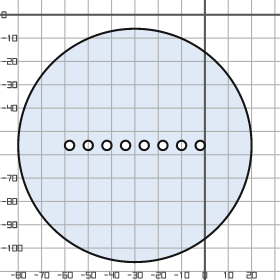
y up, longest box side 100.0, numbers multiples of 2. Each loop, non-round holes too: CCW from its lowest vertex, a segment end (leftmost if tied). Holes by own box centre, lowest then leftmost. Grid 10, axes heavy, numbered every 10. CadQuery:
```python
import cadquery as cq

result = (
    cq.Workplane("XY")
    .moveTo(-30.0, -56.0)
    .circle(50.0)
    .moveTo(-58.0, -56.0)
    .circle(2.0)
    .moveTo(-50.0, -56.0)
    .circle(2.0)
    .moveTo(-42.0, -56.0)
    .circle(2.0)
    .moveTo(-34.0, -56.0)
    .circle(2.0)
    .moveTo(-26.0, -56.0)
    .circle(2.0)
    .moveTo(-18.0, -56.0)
    .circle(2.0)
    .moveTo(-10.0, -56.0)
    .circle(2.0)
    .moveTo(-2.0, -56.0)
    .circle(2.0)
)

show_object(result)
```